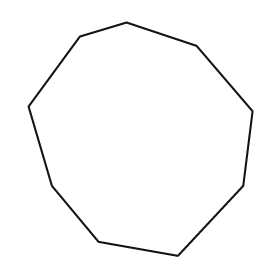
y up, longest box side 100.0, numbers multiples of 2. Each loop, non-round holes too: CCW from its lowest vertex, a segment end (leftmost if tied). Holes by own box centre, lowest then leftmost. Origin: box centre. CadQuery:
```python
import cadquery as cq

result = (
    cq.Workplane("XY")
    .moveTo(16.0, -50.0)
    .lineTo(44.0, -20.0)
    .lineTo(48.0, 12.0)
    .lineTo(24.0, 40.0)
    .lineTo(-6.0, 50.0)
    .lineTo(-26.0, 44.0)
    .lineTo(-48.0, 14.0)
    .lineTo(-38.0, -20.0)
    .lineTo(-18.0, -44.0)
    .close()
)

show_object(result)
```